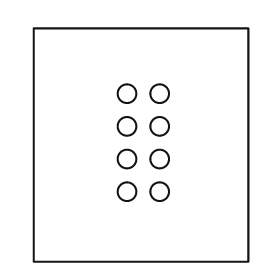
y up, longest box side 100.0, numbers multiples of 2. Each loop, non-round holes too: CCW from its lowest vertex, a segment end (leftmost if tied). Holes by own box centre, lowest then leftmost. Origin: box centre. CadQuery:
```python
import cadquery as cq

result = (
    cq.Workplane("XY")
    .moveTo(-46.0, -50.0)
    .lineTo(46.0, -50.0)
    .lineTo(46.0, 50.0)
    .lineTo(-46.0, 50.0)
    .close()
    .moveTo(-6.0, -20.0)
    .circle(4.0)
    .moveTo(8.0, -20.0)
    .circle(4.0)
    .moveTo(-6.0, -6.0)
    .circle(4.0)
    .moveTo(8.0, -6.0)
    .circle(4.0)
    .moveTo(-6.0, 8.0)
    .circle(4.0)
    .moveTo(8.0, 8.0)
    .circle(4.0)
    .moveTo(-6.0, 22.0)
    .circle(4.0)
    .moveTo(8.0, 22.0)
    .circle(4.0)
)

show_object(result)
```